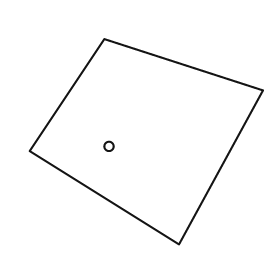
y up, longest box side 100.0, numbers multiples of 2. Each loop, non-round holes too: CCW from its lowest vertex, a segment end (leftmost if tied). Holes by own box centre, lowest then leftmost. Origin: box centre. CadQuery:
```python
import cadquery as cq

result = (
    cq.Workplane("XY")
    .moveTo(14.0, -44.0)
    .lineTo(50.0, 22.0)
    .lineTo(-18.0, 44.0)
    .lineTo(-50.0, -4.0)
    .close()
    .moveTo(-16.0, -2.0)
    .circle(2.0)
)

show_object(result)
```